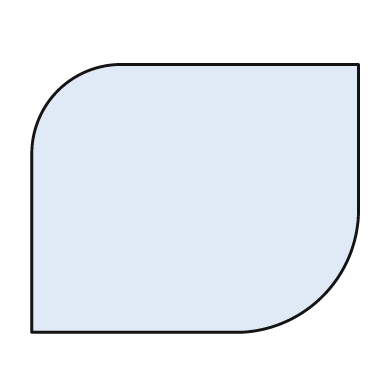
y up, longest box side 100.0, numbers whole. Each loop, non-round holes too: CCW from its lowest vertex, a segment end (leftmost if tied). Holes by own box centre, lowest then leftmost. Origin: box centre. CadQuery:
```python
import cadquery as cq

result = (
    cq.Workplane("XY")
    .moveTo(-50.0, -41.0)
    .lineTo(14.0, -41.0)
    .threePointArc((39.0, -30.0), (50.0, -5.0))
    .lineTo(50.0, 41.0)
    .lineTo(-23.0, 41.0)
    .threePointArc((-42.0, 33.0), (-50.0, 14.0))
    .close()
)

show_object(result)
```